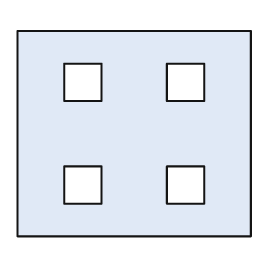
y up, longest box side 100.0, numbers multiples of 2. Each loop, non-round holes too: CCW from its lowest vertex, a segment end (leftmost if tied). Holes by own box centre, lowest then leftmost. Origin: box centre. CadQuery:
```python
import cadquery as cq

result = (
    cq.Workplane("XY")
    .moveTo(-50.0, -44.0)
    .lineTo(50.0, -44.0)
    .lineTo(50.0, 44.0)
    .lineTo(-50.0, 44.0)
    .close()
    .moveTo(-30.0, -30.0)
    .lineTo(-14.0, -30.0)
    .lineTo(-14.0, -14.0)
    .lineTo(-30.0, -14.0)
    .close()
    .moveTo(14.0, -30.0)
    .lineTo(30.0, -30.0)
    .lineTo(30.0, -14.0)
    .lineTo(14.0, -14.0)
    .close()
    .moveTo(-30.0, 14.0)
    .lineTo(-14.0, 14.0)
    .lineTo(-14.0, 30.0)
    .lineTo(-30.0, 30.0)
    .close()
    .moveTo(14.0, 14.0)
    .lineTo(30.0, 14.0)
    .lineTo(30.0, 30.0)
    .lineTo(14.0, 30.0)
    .close()
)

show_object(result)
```